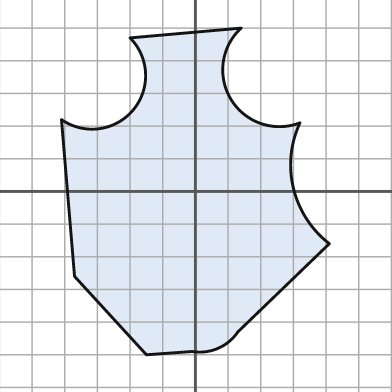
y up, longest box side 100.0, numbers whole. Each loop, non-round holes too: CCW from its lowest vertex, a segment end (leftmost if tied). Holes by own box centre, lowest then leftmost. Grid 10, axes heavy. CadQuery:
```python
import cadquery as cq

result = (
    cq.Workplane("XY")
    .moveTo(-15.0, -50.0)
    .lineTo(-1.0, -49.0)
    .threePointArc((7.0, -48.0), (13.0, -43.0))
    .lineTo(41.0, -16.0)
    .threePointArc((30.0, 1.0), (32.0, 21.0))
    .threePointArc((11.0, 28.0), (14.0, 50.0))
    .lineTo(-20.0, 47.0)
    .threePointArc((-19.0, 25.0), (-41.0, 22.0))
    .lineTo(-37.0, -26.0)
    .close()
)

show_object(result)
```